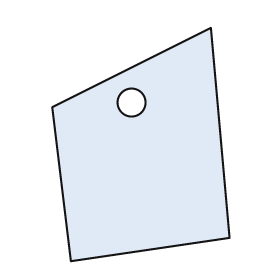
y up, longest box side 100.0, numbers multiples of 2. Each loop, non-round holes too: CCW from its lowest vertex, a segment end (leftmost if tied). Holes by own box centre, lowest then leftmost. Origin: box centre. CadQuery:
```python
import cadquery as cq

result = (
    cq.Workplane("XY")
    .moveTo(-30.0, -50.0)
    .lineTo(38.0, -40.0)
    .lineTo(30.0, 50.0)
    .lineTo(-38.0, 16.0)
    .close()
    .moveTo(-4.0, 18.0)
    .circle(6.0)
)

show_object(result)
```